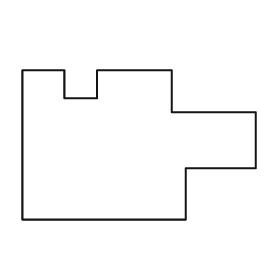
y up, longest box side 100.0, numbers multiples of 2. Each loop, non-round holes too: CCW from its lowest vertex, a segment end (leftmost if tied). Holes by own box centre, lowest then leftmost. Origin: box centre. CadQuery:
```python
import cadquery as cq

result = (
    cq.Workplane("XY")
    .moveTo(-50.0, -32.0)
    .lineTo(20.0, -32.0)
    .lineTo(20.0, -10.0)
    .lineTo(50.0, -10.0)
    .lineTo(50.0, 14.0)
    .lineTo(14.0, 14.0)
    .lineTo(14.0, 32.0)
    .lineTo(-18.0, 32.0)
    .lineTo(-18.0, 20.0)
    .lineTo(-32.0, 20.0)
    .lineTo(-32.0, 32.0)
    .lineTo(-50.0, 32.0)
    .close()
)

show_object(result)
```